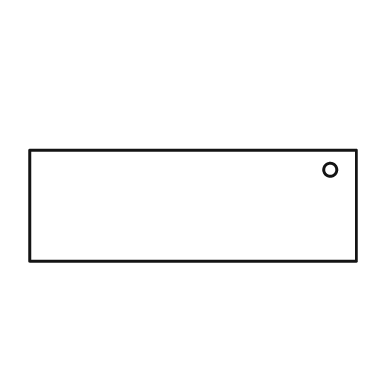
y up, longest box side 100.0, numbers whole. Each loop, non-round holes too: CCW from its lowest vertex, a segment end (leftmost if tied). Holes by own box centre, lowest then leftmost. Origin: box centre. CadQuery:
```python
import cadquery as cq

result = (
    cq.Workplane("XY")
    .moveTo(-50.0, -17.0)
    .lineTo(50.0, -17.0)
    .lineTo(50.0, 17.0)
    .lineTo(-50.0, 17.0)
    .close()
    .moveTo(42.0, 11.0)
    .circle(2.0)
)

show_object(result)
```